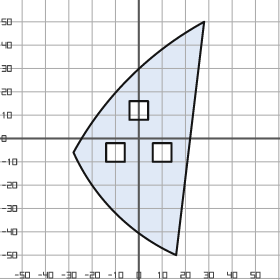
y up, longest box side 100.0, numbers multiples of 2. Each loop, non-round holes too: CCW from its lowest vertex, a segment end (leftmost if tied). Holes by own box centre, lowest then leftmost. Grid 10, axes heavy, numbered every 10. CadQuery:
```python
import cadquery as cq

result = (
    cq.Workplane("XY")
    .moveTo(16.0, -50.0)
    .lineTo(28.0, 50.0)
    .threePointArc((-4.0, 26.0), (-28.0, -6.0))
    .threePointArc((-10.0, -32.0), (16.0, -50.0))
    .close()
    .moveTo(-14.0, -10.0)
    .lineTo(-6.0, -10.0)
    .lineTo(-6.0, -2.0)
    .lineTo(-14.0, -2.0)
    .close()
    .moveTo(6.0, -10.0)
    .lineTo(14.0, -10.0)
    .lineTo(14.0, -2.0)
    .lineTo(6.0, -2.0)
    .close()
    .moveTo(-4.0, 8.0)
    .lineTo(4.0, 8.0)
    .lineTo(4.0, 16.0)
    .lineTo(-4.0, 16.0)
    .close()
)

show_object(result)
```